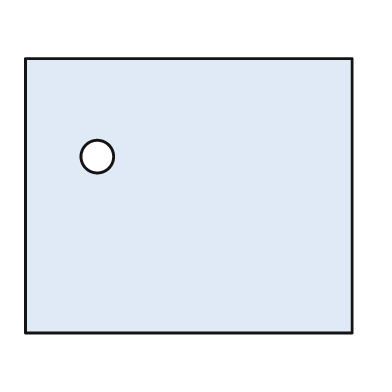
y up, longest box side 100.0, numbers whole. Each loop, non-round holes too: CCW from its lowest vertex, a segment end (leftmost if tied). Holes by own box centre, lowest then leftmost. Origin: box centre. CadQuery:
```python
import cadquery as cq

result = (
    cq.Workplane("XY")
    .moveTo(-50.0, -42.0)
    .lineTo(50.0, -42.0)
    .lineTo(50.0, 42.0)
    .lineTo(-50.0, 42.0)
    .close()
    .moveTo(-28.0, 12.0)
    .circle(5.0)
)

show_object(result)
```